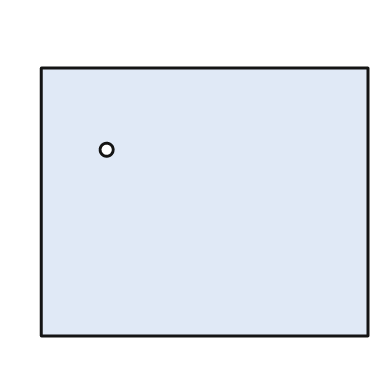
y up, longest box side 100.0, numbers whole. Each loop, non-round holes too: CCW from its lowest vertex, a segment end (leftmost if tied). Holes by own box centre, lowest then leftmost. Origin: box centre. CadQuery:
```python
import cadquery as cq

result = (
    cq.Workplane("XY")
    .moveTo(-50.0, -41.0)
    .lineTo(50.0, -41.0)
    .lineTo(50.0, 41.0)
    .lineTo(-50.0, 41.0)
    .close()
    .moveTo(-30.0, 16.0)
    .circle(2.0)
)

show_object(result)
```